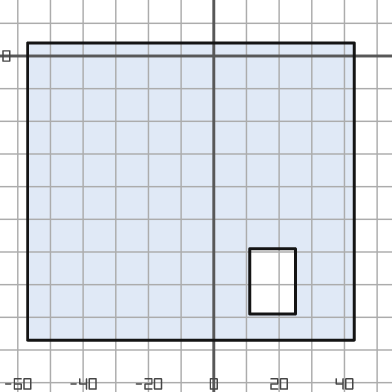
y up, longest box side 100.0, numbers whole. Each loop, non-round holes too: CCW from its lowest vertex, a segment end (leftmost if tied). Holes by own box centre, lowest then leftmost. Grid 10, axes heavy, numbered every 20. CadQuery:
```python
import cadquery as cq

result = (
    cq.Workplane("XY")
    .moveTo(-57.0, -87.0)
    .lineTo(43.0, -87.0)
    .lineTo(43.0, 4.0)
    .lineTo(-57.0, 4.0)
    .close()
    .moveTo(11.0, -79.0)
    .lineTo(25.0, -79.0)
    .lineTo(25.0, -59.0)
    .lineTo(11.0, -59.0)
    .close()
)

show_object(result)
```